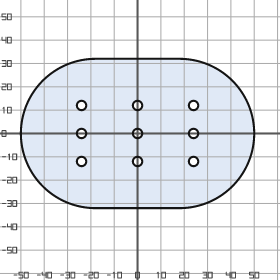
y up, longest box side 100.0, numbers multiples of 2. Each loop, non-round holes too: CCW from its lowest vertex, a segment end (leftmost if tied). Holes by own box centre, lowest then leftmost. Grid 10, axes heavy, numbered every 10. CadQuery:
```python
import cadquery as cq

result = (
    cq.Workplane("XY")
    .moveTo(-18.0, -32.0)
    .lineTo(18.0, -32.0)
    .threePointArc((50.0, 0.0), (18.0, 32.0))
    .lineTo(-18.0, 32.0)
    .threePointArc((-50.0, 0.0), (-18.0, -32.0))
    .close()
    .moveTo(-24.0, -12.0)
    .circle(2.0)
    .moveTo(0.0, -12.0)
    .circle(2.0)
    .moveTo(24.0, -12.0)
    .circle(2.0)
    .moveTo(-24.0, 0.0)
    .circle(2.0)
    .moveTo(0.0, 0.0)
    .circle(2.0)
    .moveTo(24.0, 0.0)
    .circle(2.0)
    .moveTo(-24.0, 12.0)
    .circle(2.0)
    .moveTo(0.0, 12.0)
    .circle(2.0)
    .moveTo(24.0, 12.0)
    .circle(2.0)
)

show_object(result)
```